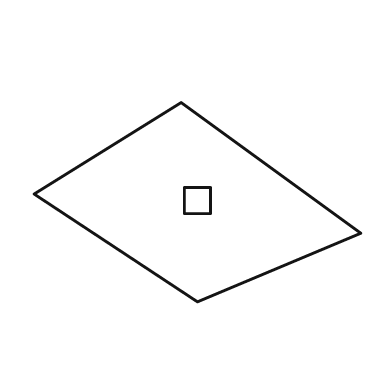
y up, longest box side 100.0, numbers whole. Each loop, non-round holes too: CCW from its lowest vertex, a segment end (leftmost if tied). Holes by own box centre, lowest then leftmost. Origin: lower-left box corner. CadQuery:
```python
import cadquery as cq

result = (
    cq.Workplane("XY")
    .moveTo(50.0, 0.0)
    .lineTo(100.0, 21.0)
    .lineTo(45.0, 61.0)
    .lineTo(0.0, 33.0)
    .close()
    .moveTo(46.0, 27.0)
    .lineTo(54.0, 27.0)
    .lineTo(54.0, 35.0)
    .lineTo(46.0, 35.0)
    .close()
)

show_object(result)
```